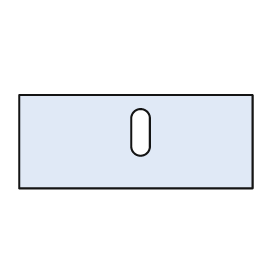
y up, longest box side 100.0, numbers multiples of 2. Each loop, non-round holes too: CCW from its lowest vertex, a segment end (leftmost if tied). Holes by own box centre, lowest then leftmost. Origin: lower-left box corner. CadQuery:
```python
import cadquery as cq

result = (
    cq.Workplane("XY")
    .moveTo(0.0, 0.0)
    .lineTo(100.0, 0.0)
    .lineTo(100.0, 40.0)
    .lineTo(0.0, 40.0)
    .close()
    .moveTo(48.0, 18.0)
    .threePointArc((52.0, 14.0), (56.0, 18.0))
    .lineTo(56.0, 30.0)
    .threePointArc((52.0, 34.0), (48.0, 30.0))
    .close()
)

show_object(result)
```